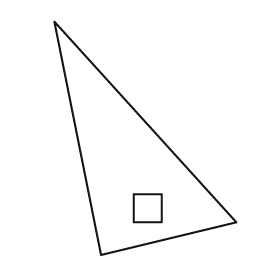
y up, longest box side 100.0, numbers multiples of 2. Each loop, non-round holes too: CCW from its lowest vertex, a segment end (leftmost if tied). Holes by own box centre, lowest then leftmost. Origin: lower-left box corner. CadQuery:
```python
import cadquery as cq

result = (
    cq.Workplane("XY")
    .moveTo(20.0, 0.0)
    .lineTo(78.0, 14.0)
    .lineTo(0.0, 100.0)
    .close()
    .moveTo(34.0, 14.0)
    .lineTo(46.0, 14.0)
    .lineTo(46.0, 26.0)
    .lineTo(34.0, 26.0)
    .close()
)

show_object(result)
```